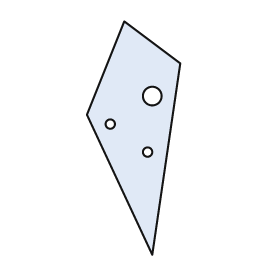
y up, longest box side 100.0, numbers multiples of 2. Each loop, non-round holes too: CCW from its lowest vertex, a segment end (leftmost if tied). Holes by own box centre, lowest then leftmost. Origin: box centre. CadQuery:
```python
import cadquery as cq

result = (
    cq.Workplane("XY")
    .moveTo(8.0, -50.0)
    .lineTo(20.0, 32.0)
    .lineTo(-4.0, 50.0)
    .lineTo(-20.0, 10.0)
    .close()
    .moveTo(6.0, -6.0)
    .circle(2.0)
    .moveTo(-10.0, 6.0)
    .circle(2.0)
    .moveTo(8.0, 18.0)
    .circle(4.0)
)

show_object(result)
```